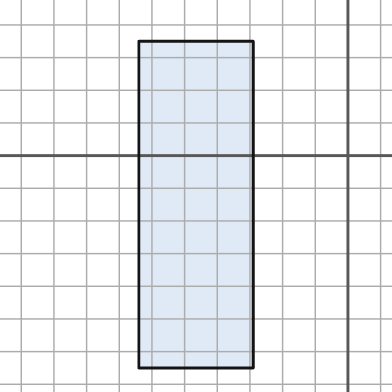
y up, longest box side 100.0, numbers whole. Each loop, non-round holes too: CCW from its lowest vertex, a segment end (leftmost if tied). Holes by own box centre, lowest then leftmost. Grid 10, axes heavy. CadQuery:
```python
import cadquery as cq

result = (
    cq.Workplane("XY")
    .moveTo(-64.0, -65.0)
    .lineTo(-29.0, -65.0)
    .lineTo(-29.0, 35.0)
    .lineTo(-64.0, 35.0)
    .close()
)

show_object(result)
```